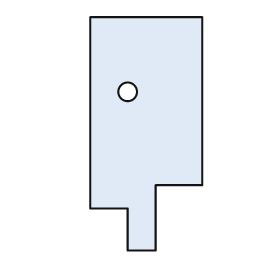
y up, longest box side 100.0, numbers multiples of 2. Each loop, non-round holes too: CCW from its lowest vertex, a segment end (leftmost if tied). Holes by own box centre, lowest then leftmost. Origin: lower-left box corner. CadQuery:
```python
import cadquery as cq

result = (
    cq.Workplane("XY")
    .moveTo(16.0, 0.0)
    .lineTo(28.0, 0.0)
    .lineTo(28.0, 28.0)
    .lineTo(48.0, 28.0)
    .lineTo(48.0, 100.0)
    .lineTo(0.0, 100.0)
    .lineTo(0.0, 18.0)
    .lineTo(16.0, 18.0)
    .close()
    .moveTo(16.0, 68.0)
    .circle(4.0)
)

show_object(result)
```